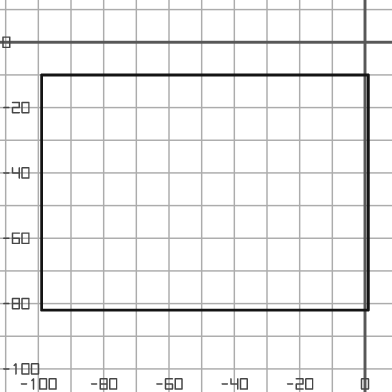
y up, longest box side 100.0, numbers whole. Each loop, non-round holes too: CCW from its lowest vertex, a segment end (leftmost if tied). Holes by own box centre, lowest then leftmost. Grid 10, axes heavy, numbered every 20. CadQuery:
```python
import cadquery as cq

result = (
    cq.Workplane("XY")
    .moveTo(-99.0, -82.0)
    .lineTo(1.0, -82.0)
    .lineTo(1.0, -10.0)
    .lineTo(-99.0, -10.0)
    .close()
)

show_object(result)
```